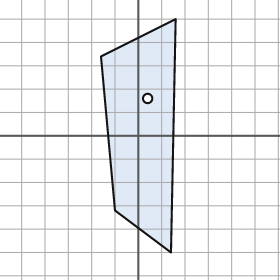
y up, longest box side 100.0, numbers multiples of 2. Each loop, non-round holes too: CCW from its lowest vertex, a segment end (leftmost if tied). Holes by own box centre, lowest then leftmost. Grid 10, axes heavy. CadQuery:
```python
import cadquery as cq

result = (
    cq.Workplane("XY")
    .moveTo(14.0, -50.0)
    .lineTo(16.0, 50.0)
    .lineTo(-16.0, 34.0)
    .lineTo(-10.0, -32.0)
    .close()
    .moveTo(4.0, 16.0)
    .circle(2.0)
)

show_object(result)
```